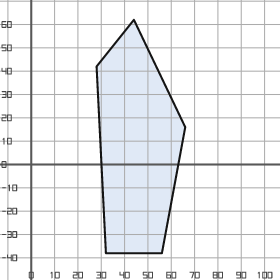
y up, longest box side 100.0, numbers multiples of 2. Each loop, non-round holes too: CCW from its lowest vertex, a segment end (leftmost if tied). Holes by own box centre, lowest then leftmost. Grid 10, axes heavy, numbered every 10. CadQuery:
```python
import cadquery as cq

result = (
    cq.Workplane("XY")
    .moveTo(32.0, -38.0)
    .lineTo(56.0, -38.0)
    .lineTo(66.0, 16.0)
    .lineTo(44.0, 62.0)
    .lineTo(28.0, 42.0)
    .close()
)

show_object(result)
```